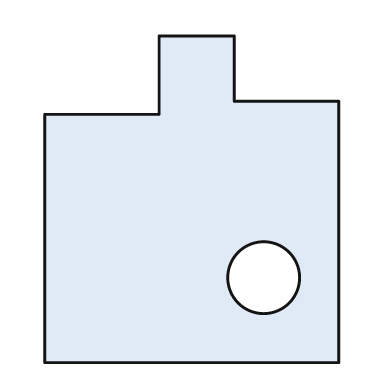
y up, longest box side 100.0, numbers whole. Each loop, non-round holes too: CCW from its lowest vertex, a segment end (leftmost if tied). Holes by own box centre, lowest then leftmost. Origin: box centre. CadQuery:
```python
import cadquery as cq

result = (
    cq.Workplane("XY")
    .moveTo(-45.0, -50.0)
    .lineTo(45.0, -50.0)
    .lineTo(45.0, 30.0)
    .lineTo(13.0, 30.0)
    .lineTo(13.0, 50.0)
    .lineTo(-10.0, 50.0)
    .lineTo(-10.0, 26.0)
    .lineTo(-45.0, 26.0)
    .close()
    .moveTo(22.0, -24.0)
    .circle(11.0)
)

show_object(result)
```